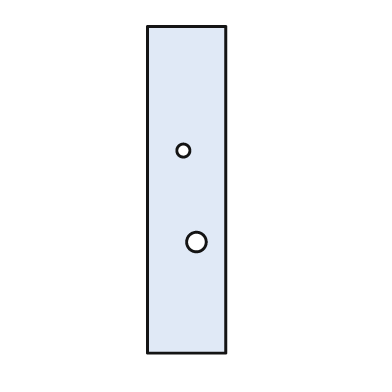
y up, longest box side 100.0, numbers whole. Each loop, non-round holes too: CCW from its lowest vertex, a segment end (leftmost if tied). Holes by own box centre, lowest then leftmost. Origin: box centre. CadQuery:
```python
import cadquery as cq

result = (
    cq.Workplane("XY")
    .moveTo(-12.0, -50.0)
    .lineTo(12.0, -50.0)
    .lineTo(12.0, 50.0)
    .lineTo(-12.0, 50.0)
    .close()
    .moveTo(3.0, -16.0)
    .circle(3.0)
    .moveTo(-1.0, 12.0)
    .circle(2.0)
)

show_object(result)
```